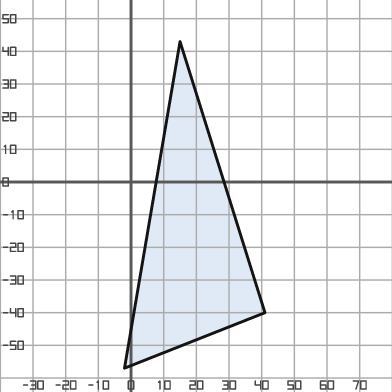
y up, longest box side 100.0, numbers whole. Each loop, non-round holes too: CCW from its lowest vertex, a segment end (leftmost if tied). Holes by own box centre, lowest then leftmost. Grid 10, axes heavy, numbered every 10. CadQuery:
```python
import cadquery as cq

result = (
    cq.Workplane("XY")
    .moveTo(-2.0, -57.0)
    .lineTo(41.0, -40.0)
    .lineTo(15.0, 43.0)
    .close()
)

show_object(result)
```